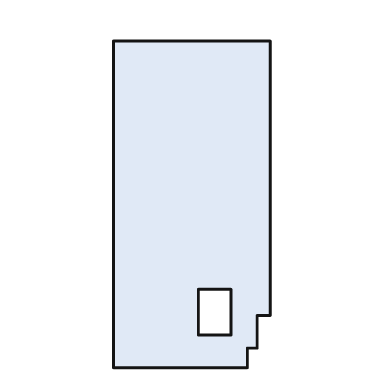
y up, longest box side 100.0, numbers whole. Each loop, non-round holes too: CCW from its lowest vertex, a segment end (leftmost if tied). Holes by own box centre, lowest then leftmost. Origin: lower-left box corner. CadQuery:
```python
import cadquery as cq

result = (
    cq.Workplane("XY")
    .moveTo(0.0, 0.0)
    .lineTo(41.0, 0.0)
    .lineTo(41.0, 6.0)
    .lineTo(44.0, 6.0)
    .lineTo(44.0, 16.0)
    .lineTo(48.0, 16.0)
    .lineTo(48.0, 100.0)
    .lineTo(0.0, 100.0)
    .close()
    .moveTo(26.0, 10.0)
    .lineTo(36.0, 10.0)
    .lineTo(36.0, 24.0)
    .lineTo(26.0, 24.0)
    .close()
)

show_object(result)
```